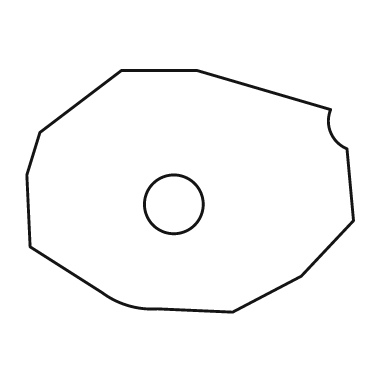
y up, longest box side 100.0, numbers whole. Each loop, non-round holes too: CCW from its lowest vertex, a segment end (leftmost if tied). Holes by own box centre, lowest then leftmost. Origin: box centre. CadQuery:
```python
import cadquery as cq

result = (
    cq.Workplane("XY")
    .moveTo(13.0, -37.0)
    .lineTo(34.0, -26.0)
    .lineTo(50.0, -9.0)
    .lineTo(48.0, 13.0)
    .threePointArc((43.0, 18.0), (43.0, 25.0))
    .lineTo(2.0, 37.0)
    .lineTo(-21.0, 37.0)
    .lineTo(-46.0, 18.0)
    .lineTo(-50.0, 5.0)
    .lineTo(-49.0, -17.0)
    .lineTo(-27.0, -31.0)
    .threePointArc((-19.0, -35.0), (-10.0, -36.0))
    .close()
    .moveTo(-5.0, -4.0)
    .circle(9.0)
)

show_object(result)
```